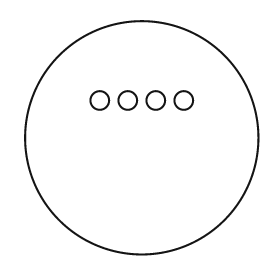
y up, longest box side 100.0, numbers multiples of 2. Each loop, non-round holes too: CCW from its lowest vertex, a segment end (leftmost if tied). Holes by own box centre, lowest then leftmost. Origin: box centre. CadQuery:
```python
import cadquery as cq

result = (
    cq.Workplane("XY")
    .moveTo(0.0, 0.0)
    .circle(50.0)
    .moveTo(-18.0, 16.0)
    .circle(4.0)
    .moveTo(-6.0, 16.0)
    .circle(4.0)
    .moveTo(6.0, 16.0)
    .circle(4.0)
    .moveTo(18.0, 16.0)
    .circle(4.0)
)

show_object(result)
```